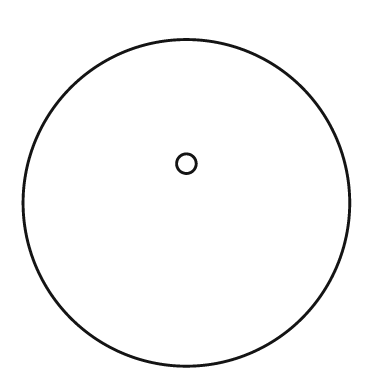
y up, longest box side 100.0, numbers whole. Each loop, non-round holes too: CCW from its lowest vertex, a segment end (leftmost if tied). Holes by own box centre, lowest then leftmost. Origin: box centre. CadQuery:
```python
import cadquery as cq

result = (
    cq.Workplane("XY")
    .moveTo(0.0, 0.0)
    .circle(50.0)
    .moveTo(0.0, 12.0)
    .circle(3.0)
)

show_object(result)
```